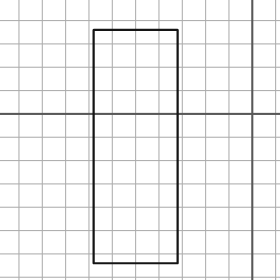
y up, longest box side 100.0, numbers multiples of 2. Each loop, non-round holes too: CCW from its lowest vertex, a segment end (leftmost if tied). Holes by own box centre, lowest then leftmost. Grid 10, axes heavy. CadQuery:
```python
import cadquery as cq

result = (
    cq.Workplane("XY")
    .moveTo(-68.0, -64.0)
    .lineTo(-32.0, -64.0)
    .lineTo(-32.0, 36.0)
    .lineTo(-68.0, 36.0)
    .close()
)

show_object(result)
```